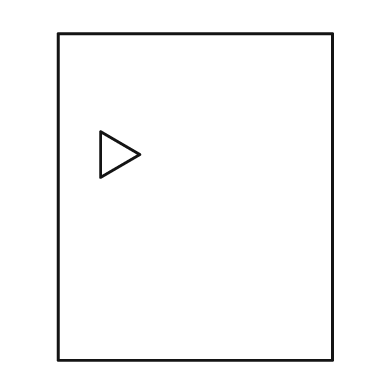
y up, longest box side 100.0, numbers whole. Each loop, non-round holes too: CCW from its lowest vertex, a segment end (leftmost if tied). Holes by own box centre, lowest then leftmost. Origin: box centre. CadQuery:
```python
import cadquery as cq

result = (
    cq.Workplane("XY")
    .moveTo(-42.0, -50.0)
    .lineTo(42.0, -50.0)
    .lineTo(42.0, 50.0)
    .lineTo(-42.0, 50.0)
    .close()
    .moveTo(-29.0, 6.0)
    .lineTo(-17.0, 13.0)
    .lineTo(-29.0, 20.0)
    .close()
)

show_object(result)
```